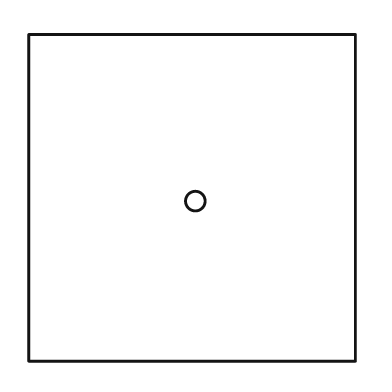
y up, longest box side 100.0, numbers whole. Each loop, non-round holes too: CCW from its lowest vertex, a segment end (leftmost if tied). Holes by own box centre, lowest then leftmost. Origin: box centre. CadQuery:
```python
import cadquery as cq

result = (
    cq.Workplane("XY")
    .moveTo(-50.0, -50.0)
    .lineTo(50.0, -50.0)
    .lineTo(50.0, 50.0)
    .lineTo(-50.0, 50.0)
    .close()
    .moveTo(1.0, -1.0)
    .circle(3.0)
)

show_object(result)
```